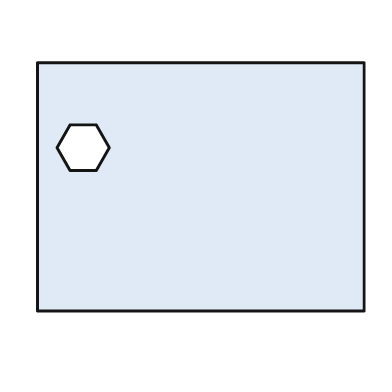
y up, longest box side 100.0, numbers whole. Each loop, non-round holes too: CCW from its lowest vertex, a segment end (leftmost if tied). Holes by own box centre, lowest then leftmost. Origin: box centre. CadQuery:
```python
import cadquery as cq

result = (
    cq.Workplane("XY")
    .moveTo(-50.0, -38.0)
    .lineTo(50.0, -38.0)
    .lineTo(50.0, 38.0)
    .lineTo(-50.0, 38.0)
    .close()
    .moveTo(-40.0, 5.0)
    .lineTo(-32.0, 5.0)
    .lineTo(-28.0, 12.0)
    .lineTo(-32.0, 19.0)
    .lineTo(-40.0, 19.0)
    .lineTo(-44.0, 12.0)
    .close()
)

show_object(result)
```